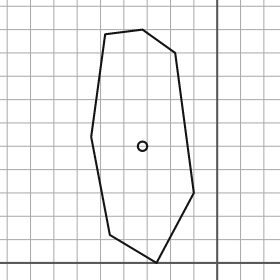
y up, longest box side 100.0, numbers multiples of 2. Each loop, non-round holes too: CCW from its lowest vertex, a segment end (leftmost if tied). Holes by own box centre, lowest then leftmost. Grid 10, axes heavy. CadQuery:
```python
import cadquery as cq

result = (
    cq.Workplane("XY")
    .moveTo(-26.0, 0.0)
    .lineTo(-10.0, 30.0)
    .lineTo(-18.0, 90.0)
    .lineTo(-32.0, 100.0)
    .lineTo(-48.0, 98.0)
    .lineTo(-54.0, 54.0)
    .lineTo(-46.0, 12.0)
    .close()
    .moveTo(-32.0, 50.0)
    .circle(2.0)
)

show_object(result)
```